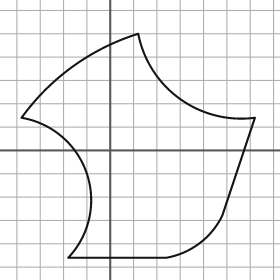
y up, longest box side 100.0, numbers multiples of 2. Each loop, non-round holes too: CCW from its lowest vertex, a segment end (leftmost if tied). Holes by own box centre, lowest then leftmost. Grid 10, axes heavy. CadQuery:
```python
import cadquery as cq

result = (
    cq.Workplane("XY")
    .moveTo(-18.0, -46.0)
    .lineTo(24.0, -46.0)
    .threePointArc((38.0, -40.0), (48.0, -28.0))
    .lineTo(62.0, 14.0)
    .threePointArc((30.0, 22.0), (12.0, 50.0))
    .threePointArc((-16.0, 36.0), (-38.0, 14.0))
    .threePointArc((-10.0, -10.0), (-18.0, -46.0))
    .close()
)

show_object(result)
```